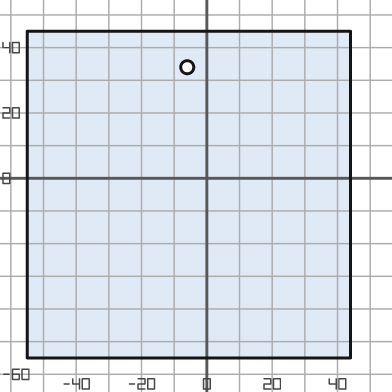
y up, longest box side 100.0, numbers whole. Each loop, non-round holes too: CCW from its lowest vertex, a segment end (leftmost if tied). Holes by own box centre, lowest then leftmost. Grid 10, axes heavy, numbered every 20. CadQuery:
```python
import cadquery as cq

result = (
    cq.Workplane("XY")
    .moveTo(-55.0, -55.0)
    .lineTo(44.0, -55.0)
    .lineTo(44.0, 45.0)
    .lineTo(-55.0, 45.0)
    .close()
    .moveTo(-6.0, 34.0)
    .circle(2.0)
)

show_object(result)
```